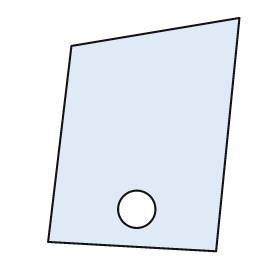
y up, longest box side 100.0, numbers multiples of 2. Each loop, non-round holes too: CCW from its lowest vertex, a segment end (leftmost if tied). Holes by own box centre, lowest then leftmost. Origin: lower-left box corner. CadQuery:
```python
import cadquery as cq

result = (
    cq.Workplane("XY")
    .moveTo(72.0, 0.0)
    .lineTo(82.0, 100.0)
    .lineTo(10.0, 88.0)
    .lineTo(0.0, 4.0)
    .close()
    .moveTo(38.0, 18.0)
    .circle(8.0)
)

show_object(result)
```